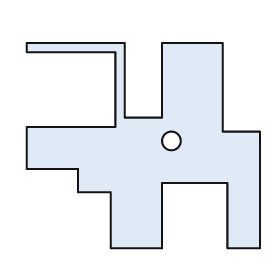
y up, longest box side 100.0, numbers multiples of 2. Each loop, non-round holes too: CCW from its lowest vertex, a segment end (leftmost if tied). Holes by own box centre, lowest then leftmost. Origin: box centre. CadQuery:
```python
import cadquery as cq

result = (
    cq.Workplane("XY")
    .moveTo(-14.0, -44.0)
    .lineTo(8.0, -44.0)
    .lineTo(8.0, -16.0)
    .lineTo(36.0, -16.0)
    .lineTo(36.0, -44.0)
    .lineTo(50.0, -44.0)
    .lineTo(50.0, 6.0)
    .lineTo(34.0, 6.0)
    .lineTo(34.0, 44.0)
    .lineTo(8.0, 44.0)
    .lineTo(8.0, 12.0)
    .lineTo(-8.0, 12.0)
    .lineTo(-8.0, 44.0)
    .lineTo(-50.0, 44.0)
    .lineTo(-50.0, 40.0)
    .lineTo(-12.0, 40.0)
    .lineTo(-12.0, 8.0)
    .lineTo(-50.0, 8.0)
    .lineTo(-50.0, -10.0)
    .lineTo(-28.0, -10.0)
    .lineTo(-28.0, -20.0)
    .lineTo(-14.0, -20.0)
    .close()
    .moveTo(12.0, 2.0)
    .circle(4.0)
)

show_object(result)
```